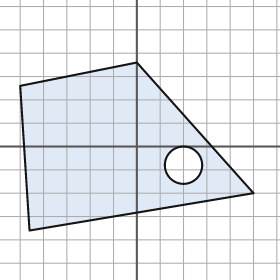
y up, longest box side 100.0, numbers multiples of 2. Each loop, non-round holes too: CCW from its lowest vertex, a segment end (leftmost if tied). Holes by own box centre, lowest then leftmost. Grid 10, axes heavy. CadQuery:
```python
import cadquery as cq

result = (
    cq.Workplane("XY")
    .moveTo(-46.0, -36.0)
    .lineTo(50.0, -20.0)
    .lineTo(0.0, 36.0)
    .lineTo(-50.0, 26.0)
    .close()
    .moveTo(20.0, -8.0)
    .circle(8.0)
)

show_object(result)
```